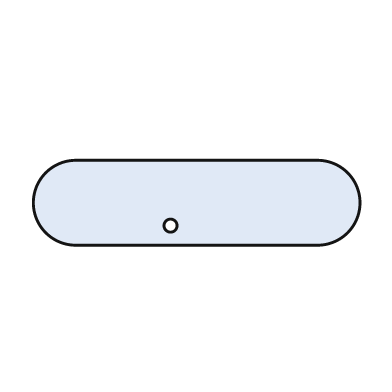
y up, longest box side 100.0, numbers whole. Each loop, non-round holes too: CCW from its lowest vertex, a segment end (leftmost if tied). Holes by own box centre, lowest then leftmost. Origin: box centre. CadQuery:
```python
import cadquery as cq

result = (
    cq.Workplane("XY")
    .moveTo(-37.0, -13.0)
    .lineTo(37.0, -13.0)
    .threePointArc((50.0, 0.0), (37.0, 13.0))
    .lineTo(-37.0, 13.0)
    .threePointArc((-50.0, 0.0), (-37.0, -13.0))
    .close()
    .moveTo(-8.0, -7.0)
    .circle(2.0)
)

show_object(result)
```